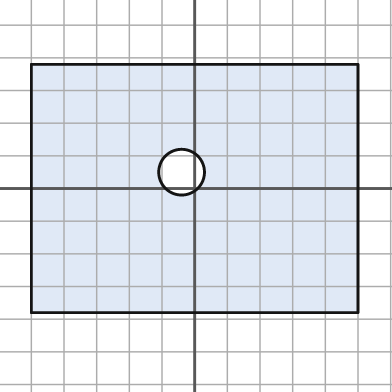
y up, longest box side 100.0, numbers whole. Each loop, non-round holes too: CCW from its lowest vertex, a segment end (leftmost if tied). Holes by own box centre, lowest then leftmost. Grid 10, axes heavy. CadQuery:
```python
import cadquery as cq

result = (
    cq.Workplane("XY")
    .moveTo(-50.0, -38.0)
    .lineTo(50.0, -38.0)
    .lineTo(50.0, 38.0)
    .lineTo(-50.0, 38.0)
    .close()
    .moveTo(-4.0, 5.0)
    .circle(7.0)
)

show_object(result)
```